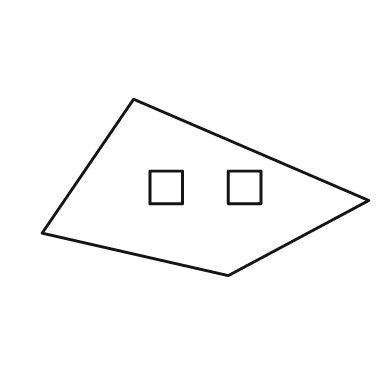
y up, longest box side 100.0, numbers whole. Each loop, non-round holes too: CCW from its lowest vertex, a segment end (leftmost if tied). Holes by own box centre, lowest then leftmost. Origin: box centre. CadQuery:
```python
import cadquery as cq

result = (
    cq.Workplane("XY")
    .moveTo(7.0, -27.0)
    .lineTo(50.0, -4.0)
    .lineTo(-22.0, 27.0)
    .lineTo(-50.0, -14.0)
    .close()
    .moveTo(-17.0, -5.0)
    .lineTo(-7.0, -5.0)
    .lineTo(-7.0, 5.0)
    .lineTo(-17.0, 5.0)
    .close()
    .moveTo(7.0, -5.0)
    .lineTo(17.0, -5.0)
    .lineTo(17.0, 5.0)
    .lineTo(7.0, 5.0)
    .close()
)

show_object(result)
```